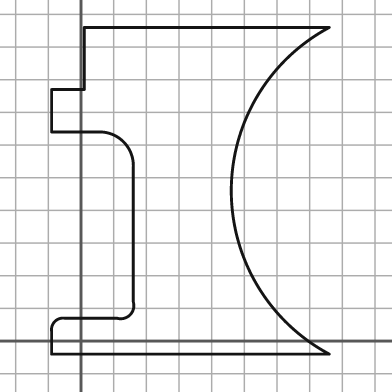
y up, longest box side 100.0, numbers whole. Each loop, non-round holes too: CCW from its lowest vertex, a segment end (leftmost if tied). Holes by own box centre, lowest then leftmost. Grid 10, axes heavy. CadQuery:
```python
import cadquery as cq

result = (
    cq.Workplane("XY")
    .moveTo(-9.0, -4.0)
    .lineTo(76.0, -4.0)
    .threePointArc((46.0, 46.0), (76.0, 96.0))
    .lineTo(1.0, 96.0)
    .lineTo(1.0, 77.0)
    .lineTo(-9.0, 77.0)
    .lineTo(-9.0, 64.0)
    .lineTo(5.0, 64.0)
    .threePointArc((13.0, 61.0), (16.0, 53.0))
    .lineTo(16.0, 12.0)
    .threePointArc((15.0, 8.0), (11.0, 7.0))
    .lineTo(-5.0, 7.0)
    .threePointArc((-8.0, 6.0), (-9.0, 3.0))
    .close()
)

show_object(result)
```